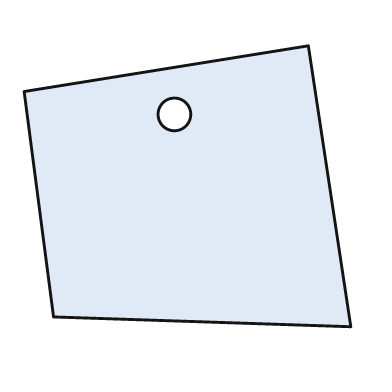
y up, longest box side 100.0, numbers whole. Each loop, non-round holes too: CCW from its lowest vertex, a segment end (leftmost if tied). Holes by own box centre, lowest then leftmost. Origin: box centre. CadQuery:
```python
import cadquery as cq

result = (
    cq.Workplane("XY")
    .moveTo(50.0, -43.0)
    .lineTo(37.0, 43.0)
    .lineTo(-50.0, 29.0)
    .lineTo(-41.0, -40.0)
    .close()
    .moveTo(-4.0, 22.0)
    .circle(5.0)
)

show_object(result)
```